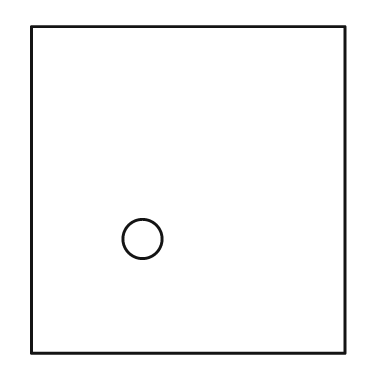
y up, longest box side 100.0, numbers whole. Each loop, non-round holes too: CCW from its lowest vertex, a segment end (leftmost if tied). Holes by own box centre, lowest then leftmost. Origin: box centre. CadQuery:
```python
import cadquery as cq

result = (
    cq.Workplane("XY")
    .moveTo(-48.0, -50.0)
    .lineTo(48.0, -50.0)
    .lineTo(48.0, 50.0)
    .lineTo(-48.0, 50.0)
    .close()
    .moveTo(-14.0, -15.0)
    .circle(6.0)
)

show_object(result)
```